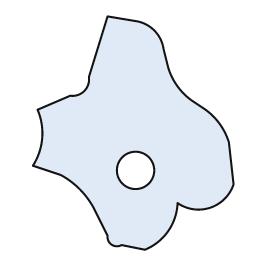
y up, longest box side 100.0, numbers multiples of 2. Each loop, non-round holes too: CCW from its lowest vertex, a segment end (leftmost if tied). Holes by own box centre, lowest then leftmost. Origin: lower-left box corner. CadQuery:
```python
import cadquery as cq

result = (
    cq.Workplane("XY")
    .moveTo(48.0, 0.0)
    .threePointArc((58.0, 8.0), (62.0, 20.0))
    .threePointArc((76.0, 18.0), (86.0, 28.0))
    .lineTo(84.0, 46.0)
    .threePointArc((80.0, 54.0), (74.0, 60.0))
    .lineTo(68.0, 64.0)
    .threePointArc((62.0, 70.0), (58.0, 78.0))
    .lineTo(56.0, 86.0)
    .threePointArc((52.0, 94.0), (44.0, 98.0))
    .lineTo(32.0, 100.0)
    .lineTo(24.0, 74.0)
    .threePointArc((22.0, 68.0), (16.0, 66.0))
    .lineTo(2.0, 60.0)
    .threePointArc((4.0, 48.0), (0.0, 36.0))
    .lineTo(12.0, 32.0)
    .threePointArc((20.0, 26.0), (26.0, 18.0))
    .lineTo(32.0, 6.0)
    .threePointArc((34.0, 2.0), (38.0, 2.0))
    .close()
    .moveTo(44.0, 34.0)
    .circle(8.0)
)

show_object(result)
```